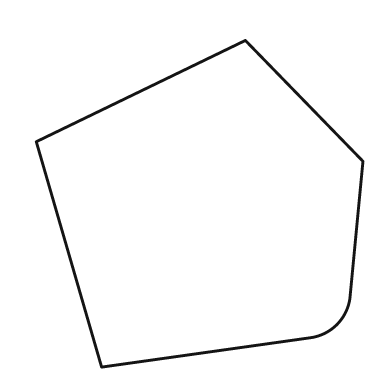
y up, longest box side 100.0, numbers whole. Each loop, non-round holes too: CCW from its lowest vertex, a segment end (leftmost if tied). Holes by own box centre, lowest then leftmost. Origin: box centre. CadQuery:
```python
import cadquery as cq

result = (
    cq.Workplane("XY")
    .moveTo(-30.0, -50.0)
    .lineTo(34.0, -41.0)
    .threePointArc((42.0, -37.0), (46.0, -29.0))
    .lineTo(50.0, 13.0)
    .lineTo(14.0, 50.0)
    .lineTo(-50.0, 19.0)
    .close()
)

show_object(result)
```